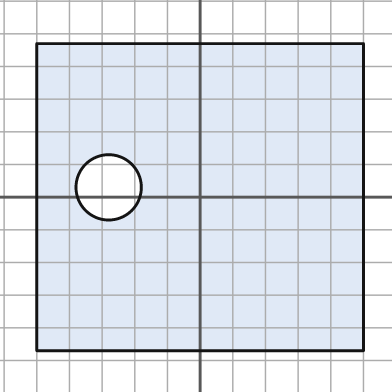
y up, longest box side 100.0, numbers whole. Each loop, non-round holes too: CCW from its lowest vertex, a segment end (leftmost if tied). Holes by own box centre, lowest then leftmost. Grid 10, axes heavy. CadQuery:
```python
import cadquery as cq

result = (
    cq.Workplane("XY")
    .moveTo(-50.0, -47.0)
    .lineTo(50.0, -47.0)
    .lineTo(50.0, 47.0)
    .lineTo(-50.0, 47.0)
    .close()
    .moveTo(-28.0, 3.0)
    .circle(10.0)
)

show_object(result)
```